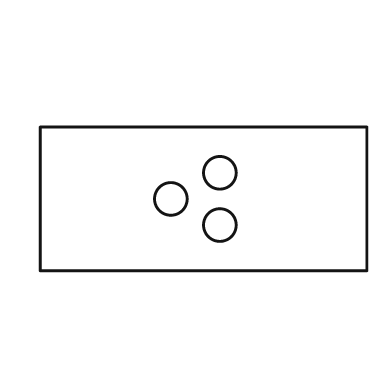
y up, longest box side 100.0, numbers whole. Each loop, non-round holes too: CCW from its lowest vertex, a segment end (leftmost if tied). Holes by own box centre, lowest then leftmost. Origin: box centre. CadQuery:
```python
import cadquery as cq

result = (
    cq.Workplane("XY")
    .moveTo(-50.0, -22.0)
    .lineTo(50.0, -22.0)
    .lineTo(50.0, 22.0)
    .lineTo(-50.0, 22.0)
    .close()
    .moveTo(5.0, -8.0)
    .circle(5.0)
    .moveTo(-10.0, 0.0)
    .circle(5.0)
    .moveTo(5.0, 8.0)
    .circle(5.0)
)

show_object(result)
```